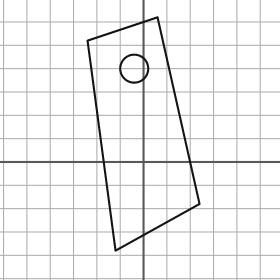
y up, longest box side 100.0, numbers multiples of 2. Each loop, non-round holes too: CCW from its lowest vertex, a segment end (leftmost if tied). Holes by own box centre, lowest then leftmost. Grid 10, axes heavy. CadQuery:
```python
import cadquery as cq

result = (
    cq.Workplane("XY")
    .moveTo(-12.0, -38.0)
    .lineTo(24.0, -18.0)
    .lineTo(6.0, 62.0)
    .lineTo(-24.0, 52.0)
    .close()
    .moveTo(-4.0, 40.0)
    .circle(6.0)
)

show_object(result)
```